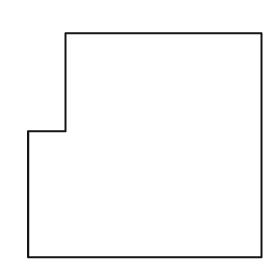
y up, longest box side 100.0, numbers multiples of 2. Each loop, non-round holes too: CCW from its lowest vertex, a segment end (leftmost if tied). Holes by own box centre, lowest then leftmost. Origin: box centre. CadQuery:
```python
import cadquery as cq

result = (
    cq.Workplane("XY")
    .moveTo(-50.0, -48.0)
    .lineTo(50.0, -48.0)
    .lineTo(50.0, 48.0)
    .lineTo(-34.0, 48.0)
    .lineTo(-34.0, 6.0)
    .lineTo(-50.0, 6.0)
    .close()
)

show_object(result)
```